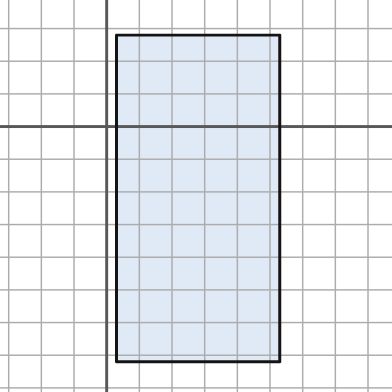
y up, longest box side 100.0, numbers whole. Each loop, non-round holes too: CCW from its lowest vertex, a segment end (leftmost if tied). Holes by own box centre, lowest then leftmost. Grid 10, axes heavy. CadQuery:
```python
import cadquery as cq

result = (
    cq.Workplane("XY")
    .moveTo(3.0, -72.0)
    .lineTo(53.0, -72.0)
    .lineTo(53.0, 28.0)
    .lineTo(3.0, 28.0)
    .close()
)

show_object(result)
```